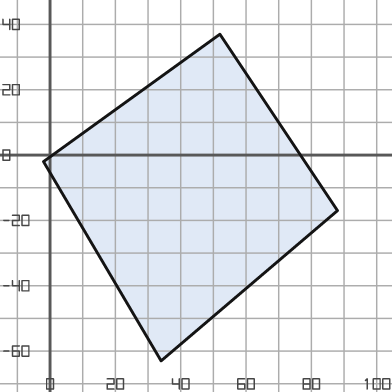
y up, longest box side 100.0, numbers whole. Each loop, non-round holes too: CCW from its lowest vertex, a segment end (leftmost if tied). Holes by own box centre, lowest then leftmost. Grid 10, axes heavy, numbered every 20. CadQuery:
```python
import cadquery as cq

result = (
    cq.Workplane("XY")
    .moveTo(34.0, -63.0)
    .lineTo(88.0, -17.0)
    .lineTo(52.0, 37.0)
    .lineTo(-2.0, -2.0)
    .close()
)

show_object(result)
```